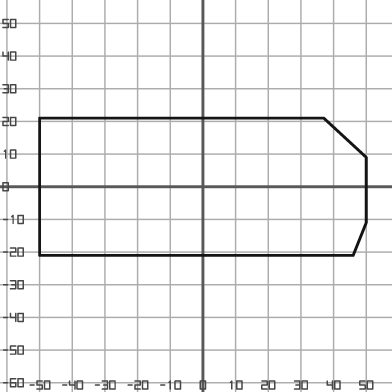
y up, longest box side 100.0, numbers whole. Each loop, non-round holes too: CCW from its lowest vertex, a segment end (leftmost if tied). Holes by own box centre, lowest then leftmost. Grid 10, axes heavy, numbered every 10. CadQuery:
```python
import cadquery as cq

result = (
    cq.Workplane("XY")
    .moveTo(-50.0, -21.0)
    .lineTo(46.0, -21.0)
    .lineTo(50.0, -11.0)
    .lineTo(50.0, 9.0)
    .lineTo(37.0, 21.0)
    .lineTo(-50.0, 21.0)
    .close()
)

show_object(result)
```